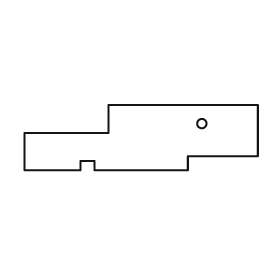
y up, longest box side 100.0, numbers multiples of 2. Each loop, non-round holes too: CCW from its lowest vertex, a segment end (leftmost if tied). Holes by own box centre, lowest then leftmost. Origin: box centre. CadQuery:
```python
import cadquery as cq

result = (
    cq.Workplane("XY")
    .moveTo(-50.0, -14.0)
    .lineTo(-26.0, -14.0)
    .lineTo(-26.0, -10.0)
    .lineTo(-20.0, -10.0)
    .lineTo(-20.0, -14.0)
    .lineTo(20.0, -14.0)
    .lineTo(20.0, -8.0)
    .lineTo(50.0, -8.0)
    .lineTo(50.0, 14.0)
    .lineTo(-14.0, 14.0)
    .lineTo(-14.0, 2.0)
    .lineTo(-50.0, 2.0)
    .close()
    .moveTo(26.0, 6.0)
    .circle(2.0)
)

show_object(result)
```